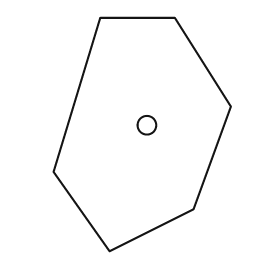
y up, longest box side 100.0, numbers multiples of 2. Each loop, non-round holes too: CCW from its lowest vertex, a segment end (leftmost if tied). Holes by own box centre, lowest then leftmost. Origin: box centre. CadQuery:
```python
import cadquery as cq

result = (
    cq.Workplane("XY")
    .moveTo(-14.0, -50.0)
    .lineTo(22.0, -32.0)
    .lineTo(38.0, 12.0)
    .lineTo(14.0, 50.0)
    .lineTo(-18.0, 50.0)
    .lineTo(-38.0, -16.0)
    .close()
    .moveTo(2.0, 4.0)
    .circle(4.0)
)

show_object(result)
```